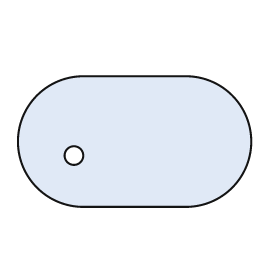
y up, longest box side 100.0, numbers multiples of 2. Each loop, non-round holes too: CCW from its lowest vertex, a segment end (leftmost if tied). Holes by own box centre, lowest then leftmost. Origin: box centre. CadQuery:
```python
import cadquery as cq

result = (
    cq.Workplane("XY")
    .moveTo(-22.0, -28.0)
    .lineTo(22.0, -28.0)
    .threePointArc((50.0, 0.0), (22.0, 28.0))
    .lineTo(-22.0, 28.0)
    .threePointArc((-50.0, 0.0), (-22.0, -28.0))
    .close()
    .moveTo(-26.0, -6.0)
    .circle(4.0)
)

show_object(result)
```